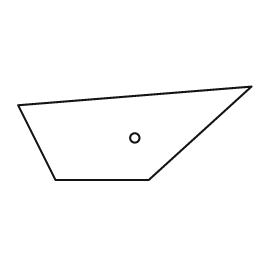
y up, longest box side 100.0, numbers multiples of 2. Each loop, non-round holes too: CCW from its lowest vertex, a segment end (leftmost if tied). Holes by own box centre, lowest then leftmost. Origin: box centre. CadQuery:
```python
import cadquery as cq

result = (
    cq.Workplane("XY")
    .moveTo(-34.0, -20.0)
    .lineTo(6.0, -20.0)
    .lineTo(50.0, 20.0)
    .lineTo(-50.0, 12.0)
    .close()
    .moveTo(0.0, -2.0)
    .circle(2.0)
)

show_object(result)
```